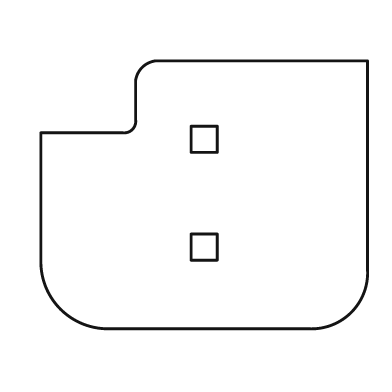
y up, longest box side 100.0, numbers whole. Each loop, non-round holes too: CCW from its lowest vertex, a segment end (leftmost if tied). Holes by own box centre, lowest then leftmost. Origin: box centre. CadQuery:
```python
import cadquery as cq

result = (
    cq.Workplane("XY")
    .moveTo(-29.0, -41.0)
    .lineTo(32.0, -41.0)
    .threePointArc((45.0, -36.0), (50.0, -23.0))
    .lineTo(50.0, 41.0)
    .lineTo(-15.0, 41.0)
    .threePointArc((-19.0, 39.0), (-21.0, 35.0))
    .lineTo(-21.0, 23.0)
    .threePointArc((-22.0, 20.0), (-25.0, 19.0))
    .lineTo(-50.0, 19.0)
    .lineTo(-50.0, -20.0)
    .threePointArc((-44.0, -35.0), (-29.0, -41.0))
    .close()
    .moveTo(-4.0, -20.0)
    .lineTo(4.0, -20.0)
    .lineTo(4.0, -12.0)
    .lineTo(-4.0, -12.0)
    .close()
    .moveTo(-4.0, 13.0)
    .lineTo(4.0, 13.0)
    .lineTo(4.0, 21.0)
    .lineTo(-4.0, 21.0)
    .close()
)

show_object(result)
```